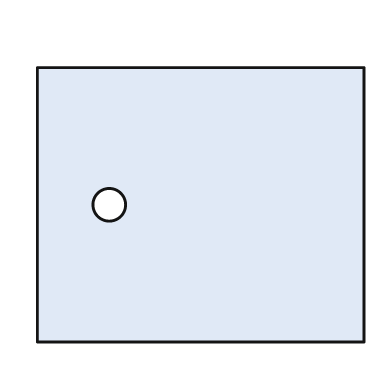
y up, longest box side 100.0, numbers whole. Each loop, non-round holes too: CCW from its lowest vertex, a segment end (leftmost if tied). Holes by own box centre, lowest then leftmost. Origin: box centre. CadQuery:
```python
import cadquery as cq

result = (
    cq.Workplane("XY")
    .moveTo(-50.0, -42.0)
    .lineTo(50.0, -42.0)
    .lineTo(50.0, 42.0)
    .lineTo(-50.0, 42.0)
    .close()
    .moveTo(-28.0, 0.0)
    .circle(5.0)
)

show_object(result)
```